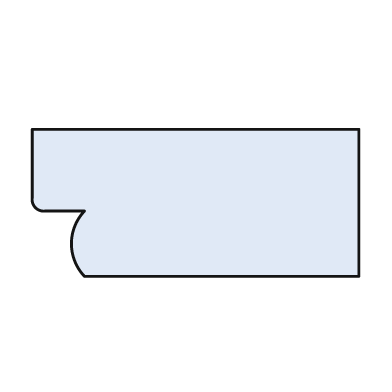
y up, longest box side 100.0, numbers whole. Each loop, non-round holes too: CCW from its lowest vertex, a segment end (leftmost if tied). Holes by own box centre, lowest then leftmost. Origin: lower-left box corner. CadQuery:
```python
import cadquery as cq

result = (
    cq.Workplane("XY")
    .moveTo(16.0, 0.0)
    .lineTo(100.0, 0.0)
    .lineTo(100.0, 45.0)
    .lineTo(0.0, 45.0)
    .lineTo(0.0, 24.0)
    .threePointArc((1.0, 21.0), (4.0, 20.0))
    .lineTo(16.0, 20.0)
    .threePointArc((12.0, 10.0), (16.0, 0.0))
    .close()
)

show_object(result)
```